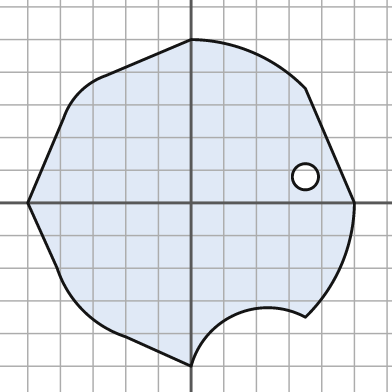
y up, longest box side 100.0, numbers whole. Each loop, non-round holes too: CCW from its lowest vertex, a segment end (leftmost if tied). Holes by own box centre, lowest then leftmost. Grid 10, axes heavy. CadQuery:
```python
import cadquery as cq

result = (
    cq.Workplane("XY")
    .moveTo(0.0, -50.0)
    .threePointArc((14.0, -34.0), (35.0, -35.0))
    .threePointArc((46.0, -19.0), (50.0, 0.0))
    .lineTo(35.0, 35.0)
    .threePointArc((19.0, 46.0), (0.0, 50.0))
    .lineTo(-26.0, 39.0)
    .threePointArc((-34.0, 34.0), (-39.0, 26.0))
    .lineTo(-50.0, 0.0)
    .lineTo(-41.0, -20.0)
    .threePointArc((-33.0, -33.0), (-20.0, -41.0))
    .close()
    .moveTo(35.0, 8.0)
    .circle(4.0)
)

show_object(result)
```